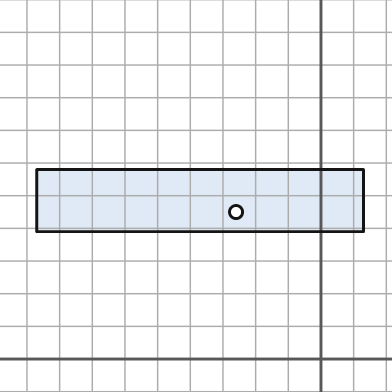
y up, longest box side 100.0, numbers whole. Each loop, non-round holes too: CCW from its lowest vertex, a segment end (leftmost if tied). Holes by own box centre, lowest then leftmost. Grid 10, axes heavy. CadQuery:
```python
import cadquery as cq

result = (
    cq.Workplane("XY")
    .moveTo(-87.0, 39.0)
    .lineTo(13.0, 39.0)
    .lineTo(13.0, 58.0)
    .lineTo(-87.0, 58.0)
    .close()
    .moveTo(-26.0, 45.0)
    .circle(2.0)
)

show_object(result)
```